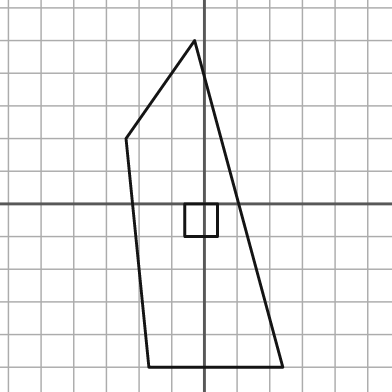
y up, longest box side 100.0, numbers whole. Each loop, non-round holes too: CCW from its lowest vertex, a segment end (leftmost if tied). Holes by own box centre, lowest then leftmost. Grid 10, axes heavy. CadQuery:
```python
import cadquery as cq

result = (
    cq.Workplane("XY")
    .moveTo(-17.0, -50.0)
    .lineTo(24.0, -50.0)
    .lineTo(-3.0, 50.0)
    .lineTo(-24.0, 20.0)
    .close()
    .moveTo(-6.0, -10.0)
    .lineTo(4.0, -10.0)
    .lineTo(4.0, 0.0)
    .lineTo(-6.0, 0.0)
    .close()
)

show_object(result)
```